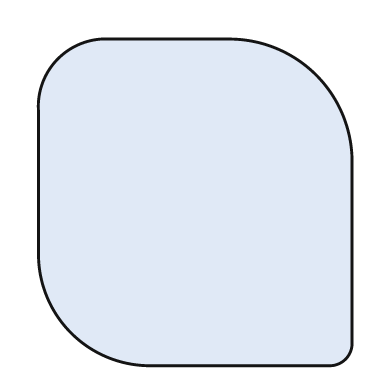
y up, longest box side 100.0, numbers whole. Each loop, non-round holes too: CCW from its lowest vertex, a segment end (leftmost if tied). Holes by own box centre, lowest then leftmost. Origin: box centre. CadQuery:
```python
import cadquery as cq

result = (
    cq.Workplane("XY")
    .moveTo(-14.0, -50.0)
    .lineTo(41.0, -50.0)
    .threePointArc((46.0, -48.0), (48.0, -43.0))
    .lineTo(48.0, 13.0)
    .threePointArc((37.0, 39.0), (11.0, 50.0))
    .lineTo(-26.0, 50.0)
    .threePointArc((-42.0, 44.0), (-48.0, 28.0))
    .lineTo(-48.0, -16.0)
    .threePointArc((-38.0, -40.0), (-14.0, -50.0))
    .close()
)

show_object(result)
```